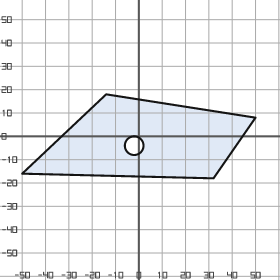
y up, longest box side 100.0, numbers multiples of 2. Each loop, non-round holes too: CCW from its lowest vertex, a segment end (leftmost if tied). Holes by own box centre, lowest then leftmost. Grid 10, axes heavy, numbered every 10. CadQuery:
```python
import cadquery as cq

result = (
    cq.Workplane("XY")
    .moveTo(32.0, -18.0)
    .lineTo(50.0, 8.0)
    .lineTo(-14.0, 18.0)
    .lineTo(-50.0, -16.0)
    .close()
    .moveTo(-2.0, -4.0)
    .circle(4.0)
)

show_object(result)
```